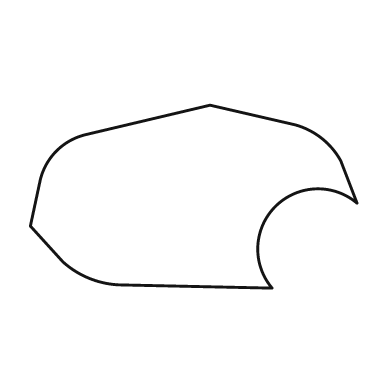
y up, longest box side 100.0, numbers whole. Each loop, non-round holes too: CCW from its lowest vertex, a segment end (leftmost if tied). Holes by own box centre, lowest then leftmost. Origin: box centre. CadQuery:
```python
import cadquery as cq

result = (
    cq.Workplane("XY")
    .moveTo(24.0, -28.0)
    .threePointArc((25.0, -3.0), (50.0, -2.0))
    .lineTo(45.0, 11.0)
    .threePointArc((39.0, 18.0), (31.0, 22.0))
    .lineTo(5.0, 28.0)
    .lineTo(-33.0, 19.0)
    .threePointArc((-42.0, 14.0), (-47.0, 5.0))
    .lineTo(-50.0, -9.0)
    .lineTo(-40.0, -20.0)
    .threePointArc((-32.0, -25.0), (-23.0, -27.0))
    .close()
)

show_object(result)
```